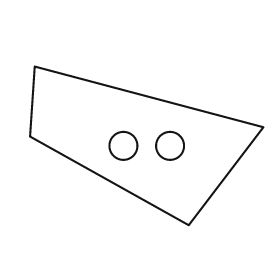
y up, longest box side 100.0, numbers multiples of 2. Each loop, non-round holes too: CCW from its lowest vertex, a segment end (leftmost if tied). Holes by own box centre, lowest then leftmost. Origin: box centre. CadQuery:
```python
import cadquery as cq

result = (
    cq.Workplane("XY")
    .moveTo(18.0, -34.0)
    .lineTo(50.0, 8.0)
    .lineTo(-48.0, 34.0)
    .lineTo(-50.0, 4.0)
    .close()
    .moveTo(-10.0, 0.0)
    .circle(6.0)
    .moveTo(10.0, 0.0)
    .circle(6.0)
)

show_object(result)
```